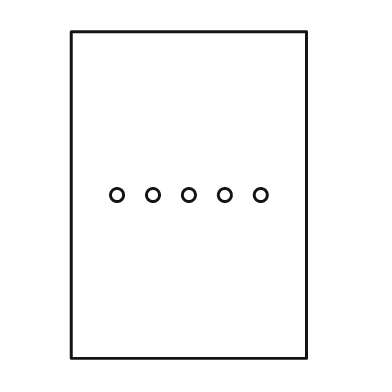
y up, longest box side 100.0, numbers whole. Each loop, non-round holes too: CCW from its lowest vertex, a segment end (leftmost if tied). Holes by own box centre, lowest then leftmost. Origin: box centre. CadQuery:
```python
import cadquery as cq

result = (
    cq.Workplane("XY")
    .moveTo(-36.0, -50.0)
    .lineTo(36.0, -50.0)
    .lineTo(36.0, 50.0)
    .lineTo(-36.0, 50.0)
    .close()
    .moveTo(-22.0, 0.0)
    .circle(2.0)
    .moveTo(-11.0, 0.0)
    .circle(2.0)
    .moveTo(0.0, 0.0)
    .circle(2.0)
    .moveTo(11.0, 0.0)
    .circle(2.0)
    .moveTo(22.0, 0.0)
    .circle(2.0)
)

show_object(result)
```